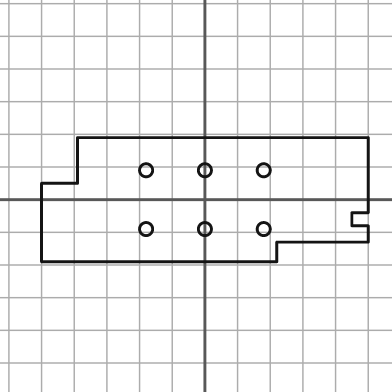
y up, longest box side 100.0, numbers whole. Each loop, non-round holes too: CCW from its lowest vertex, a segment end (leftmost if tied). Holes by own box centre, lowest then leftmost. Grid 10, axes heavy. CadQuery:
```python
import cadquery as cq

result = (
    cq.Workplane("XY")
    .moveTo(-50.0, -19.0)
    .lineTo(22.0, -19.0)
    .lineTo(22.0, -13.0)
    .lineTo(50.0, -13.0)
    .lineTo(50.0, -8.0)
    .lineTo(45.0, -8.0)
    .lineTo(45.0, -4.0)
    .lineTo(50.0, -4.0)
    .lineTo(50.0, 19.0)
    .lineTo(-39.0, 19.0)
    .lineTo(-39.0, 5.0)
    .lineTo(-50.0, 5.0)
    .close()
    .moveTo(-18.0, -9.0)
    .circle(2.0)
    .moveTo(0.0, -9.0)
    .circle(2.0)
    .moveTo(18.0, -9.0)
    .circle(2.0)
    .moveTo(-18.0, 9.0)
    .circle(2.0)
    .moveTo(0.0, 9.0)
    .circle(2.0)
    .moveTo(18.0, 9.0)
    .circle(2.0)
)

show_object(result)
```